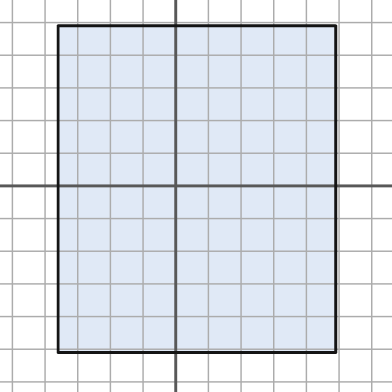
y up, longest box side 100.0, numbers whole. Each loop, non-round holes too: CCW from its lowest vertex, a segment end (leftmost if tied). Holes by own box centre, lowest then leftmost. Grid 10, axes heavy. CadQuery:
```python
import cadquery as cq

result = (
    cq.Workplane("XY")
    .moveTo(-36.0, -51.0)
    .lineTo(49.0, -51.0)
    .lineTo(49.0, 49.0)
    .lineTo(-36.0, 49.0)
    .close()
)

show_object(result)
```